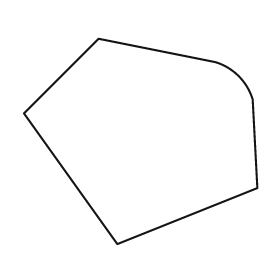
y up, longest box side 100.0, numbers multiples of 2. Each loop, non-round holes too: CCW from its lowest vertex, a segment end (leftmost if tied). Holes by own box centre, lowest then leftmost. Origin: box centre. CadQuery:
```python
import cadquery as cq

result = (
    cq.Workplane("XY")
    .moveTo(-10.0, -44.0)
    .lineTo(50.0, -20.0)
    .lineTo(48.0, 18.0)
    .threePointArc((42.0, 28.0), (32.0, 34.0))
    .lineTo(-18.0, 44.0)
    .lineTo(-50.0, 12.0)
    .close()
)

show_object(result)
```